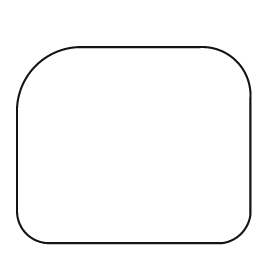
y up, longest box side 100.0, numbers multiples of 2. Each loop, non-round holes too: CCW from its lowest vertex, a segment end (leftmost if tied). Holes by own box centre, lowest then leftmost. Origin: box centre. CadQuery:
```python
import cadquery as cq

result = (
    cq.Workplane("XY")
    .moveTo(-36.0, -42.0)
    .lineTo(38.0, -42.0)
    .threePointArc((46.0, -38.0), (50.0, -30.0))
    .lineTo(50.0, 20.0)
    .threePointArc((44.0, 36.0), (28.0, 42.0))
    .lineTo(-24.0, 42.0)
    .threePointArc((-42.0, 34.0), (-50.0, 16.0))
    .lineTo(-50.0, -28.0)
    .threePointArc((-46.0, -38.0), (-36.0, -42.0))
    .close()
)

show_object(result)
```